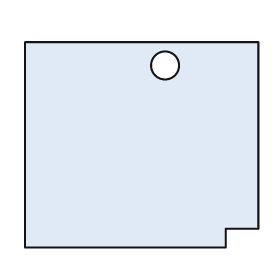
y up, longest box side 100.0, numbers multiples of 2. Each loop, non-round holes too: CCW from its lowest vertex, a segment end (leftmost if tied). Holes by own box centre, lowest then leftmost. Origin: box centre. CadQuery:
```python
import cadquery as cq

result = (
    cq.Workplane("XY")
    .moveTo(-50.0, -44.0)
    .lineTo(36.0, -44.0)
    .lineTo(36.0, -36.0)
    .lineTo(50.0, -36.0)
    .lineTo(50.0, 44.0)
    .lineTo(-50.0, 44.0)
    .close()
    .moveTo(10.0, 34.0)
    .circle(6.0)
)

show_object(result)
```